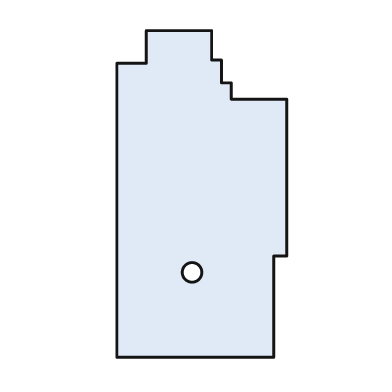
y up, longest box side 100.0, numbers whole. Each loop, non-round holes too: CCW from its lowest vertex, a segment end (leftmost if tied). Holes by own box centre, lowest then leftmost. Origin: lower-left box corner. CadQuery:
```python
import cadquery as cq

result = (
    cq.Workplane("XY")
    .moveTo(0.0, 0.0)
    .lineTo(48.0, 0.0)
    .lineTo(48.0, 31.0)
    .lineTo(52.0, 31.0)
    .lineTo(52.0, 79.0)
    .lineTo(35.0, 79.0)
    .lineTo(35.0, 84.0)
    .lineTo(32.0, 84.0)
    .lineTo(32.0, 91.0)
    .lineTo(29.0, 91.0)
    .lineTo(29.0, 100.0)
    .lineTo(9.0, 100.0)
    .lineTo(9.0, 90.0)
    .lineTo(0.0, 90.0)
    .close()
    .moveTo(23.0, 26.0)
    .circle(3.0)
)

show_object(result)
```